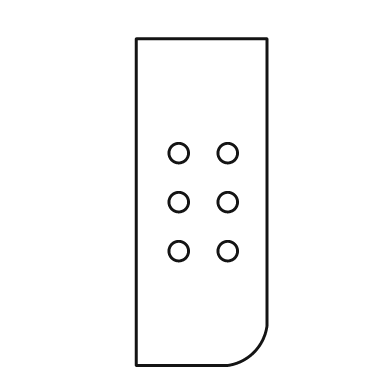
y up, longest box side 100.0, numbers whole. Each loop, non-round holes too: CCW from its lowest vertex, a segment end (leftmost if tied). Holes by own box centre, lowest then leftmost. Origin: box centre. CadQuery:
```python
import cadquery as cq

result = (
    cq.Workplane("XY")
    .moveTo(-20.0, -50.0)
    .lineTo(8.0, -50.0)
    .threePointArc((16.0, -46.0), (20.0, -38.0))
    .lineTo(20.0, 50.0)
    .lineTo(-20.0, 50.0)
    .close()
    .moveTo(-7.0, -15.0)
    .circle(3.0)
    .moveTo(8.0, -15.0)
    .circle(3.0)
    .moveTo(-7.0, 0.0)
    .circle(3.0)
    .moveTo(8.0, 0.0)
    .circle(3.0)
    .moveTo(-7.0, 15.0)
    .circle(3.0)
    .moveTo(8.0, 15.0)
    .circle(3.0)
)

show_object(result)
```